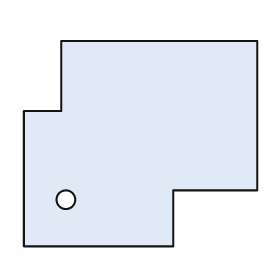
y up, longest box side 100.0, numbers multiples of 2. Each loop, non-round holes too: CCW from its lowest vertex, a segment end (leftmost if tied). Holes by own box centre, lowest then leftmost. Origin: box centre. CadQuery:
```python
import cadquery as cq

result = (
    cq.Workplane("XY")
    .moveTo(-50.0, -44.0)
    .lineTo(14.0, -44.0)
    .lineTo(14.0, -20.0)
    .lineTo(50.0, -20.0)
    .lineTo(50.0, 44.0)
    .lineTo(-34.0, 44.0)
    .lineTo(-34.0, 14.0)
    .lineTo(-50.0, 14.0)
    .close()
    .moveTo(-32.0, -24.0)
    .circle(4.0)
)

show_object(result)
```